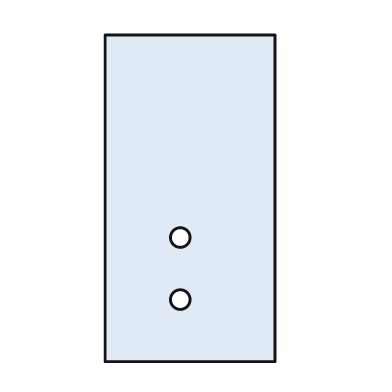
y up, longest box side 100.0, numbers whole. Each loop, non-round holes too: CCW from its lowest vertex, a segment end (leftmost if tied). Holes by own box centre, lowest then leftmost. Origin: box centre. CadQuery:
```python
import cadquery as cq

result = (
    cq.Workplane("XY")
    .moveTo(-26.0, -50.0)
    .lineTo(26.0, -50.0)
    .lineTo(26.0, 50.0)
    .lineTo(-26.0, 50.0)
    .close()
    .moveTo(-3.0, -31.0)
    .circle(3.0)
    .moveTo(-3.0, -12.0)
    .circle(3.0)
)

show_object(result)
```